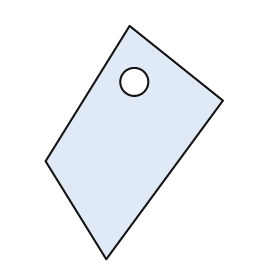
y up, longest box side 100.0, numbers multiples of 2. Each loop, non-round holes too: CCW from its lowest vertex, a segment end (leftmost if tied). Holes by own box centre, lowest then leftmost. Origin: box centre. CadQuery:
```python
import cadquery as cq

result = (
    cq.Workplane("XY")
    .moveTo(-12.0, -50.0)
    .lineTo(38.0, 18.0)
    .lineTo(-2.0, 50.0)
    .lineTo(-38.0, -8.0)
    .close()
    .moveTo(0.0, 26.0)
    .circle(6.0)
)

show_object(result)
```